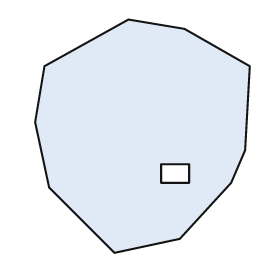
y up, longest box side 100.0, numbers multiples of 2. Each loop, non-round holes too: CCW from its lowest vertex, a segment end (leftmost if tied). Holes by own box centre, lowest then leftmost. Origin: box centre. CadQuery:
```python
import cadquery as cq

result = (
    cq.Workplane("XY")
    .moveTo(-12.0, -50.0)
    .lineTo(16.0, -44.0)
    .lineTo(38.0, -20.0)
    .lineTo(44.0, -6.0)
    .lineTo(46.0, 30.0)
    .lineTo(18.0, 46.0)
    .lineTo(-6.0, 50.0)
    .lineTo(-42.0, 30.0)
    .lineTo(-46.0, 6.0)
    .lineTo(-40.0, -22.0)
    .close()
    .moveTo(8.0, -20.0)
    .lineTo(20.0, -20.0)
    .lineTo(20.0, -12.0)
    .lineTo(8.0, -12.0)
    .close()
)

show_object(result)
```